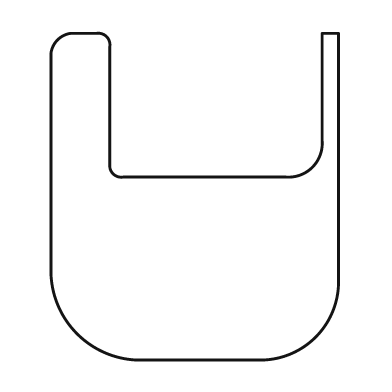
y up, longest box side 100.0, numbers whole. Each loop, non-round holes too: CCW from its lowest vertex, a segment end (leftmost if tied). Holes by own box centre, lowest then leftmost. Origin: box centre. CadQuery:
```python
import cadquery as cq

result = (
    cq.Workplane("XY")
    .moveTo(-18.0, -50.0)
    .lineTo(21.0, -50.0)
    .threePointArc((37.0, -43.0), (44.0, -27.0))
    .lineTo(44.0, 50.0)
    .lineTo(39.0, 50.0)
    .lineTo(39.0, 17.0)
    .threePointArc((36.0, 9.0), (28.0, 6.0))
    .lineTo(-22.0, 6.0)
    .threePointArc((-25.0, 7.0), (-26.0, 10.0))
    .lineTo(-26.0, 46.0)
    .threePointArc((-27.0, 49.0), (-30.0, 50.0))
    .lineTo(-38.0, 50.0)
    .threePointArc((-42.0, 48.0), (-44.0, 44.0))
    .lineTo(-44.0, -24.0)
    .threePointArc((-36.0, -42.0), (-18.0, -50.0))
    .close()
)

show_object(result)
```